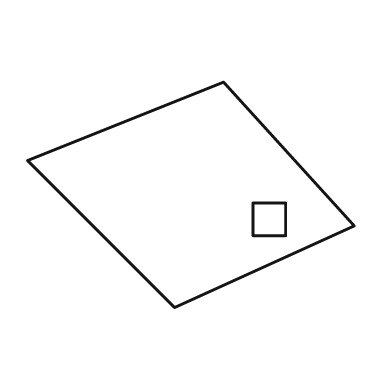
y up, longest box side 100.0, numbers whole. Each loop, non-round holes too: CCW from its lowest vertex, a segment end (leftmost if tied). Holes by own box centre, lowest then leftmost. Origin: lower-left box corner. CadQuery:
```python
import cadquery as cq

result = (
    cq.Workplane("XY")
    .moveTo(45.0, 0.0)
    .lineTo(100.0, 25.0)
    .lineTo(60.0, 69.0)
    .lineTo(0.0, 45.0)
    .close()
    .moveTo(69.0, 22.0)
    .lineTo(79.0, 22.0)
    .lineTo(79.0, 32.0)
    .lineTo(69.0, 32.0)
    .close()
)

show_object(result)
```